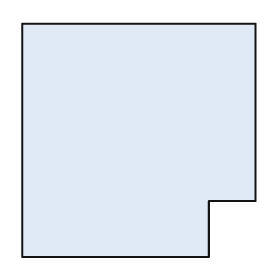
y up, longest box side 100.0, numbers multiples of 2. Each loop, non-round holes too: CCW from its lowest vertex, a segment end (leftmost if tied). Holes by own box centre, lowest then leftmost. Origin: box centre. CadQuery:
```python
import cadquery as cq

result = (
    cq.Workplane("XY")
    .moveTo(-50.0, -50.0)
    .lineTo(30.0, -50.0)
    .lineTo(30.0, -26.0)
    .lineTo(50.0, -26.0)
    .lineTo(50.0, 50.0)
    .lineTo(-50.0, 50.0)
    .close()
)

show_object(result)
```